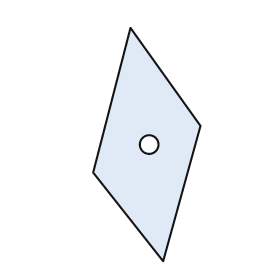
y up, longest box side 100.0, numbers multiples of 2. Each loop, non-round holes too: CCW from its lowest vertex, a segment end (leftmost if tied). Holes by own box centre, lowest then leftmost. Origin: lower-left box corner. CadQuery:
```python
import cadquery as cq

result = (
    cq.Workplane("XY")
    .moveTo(30.0, 0.0)
    .lineTo(46.0, 58.0)
    .lineTo(16.0, 100.0)
    .lineTo(0.0, 38.0)
    .close()
    .moveTo(24.0, 50.0)
    .circle(4.0)
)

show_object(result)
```